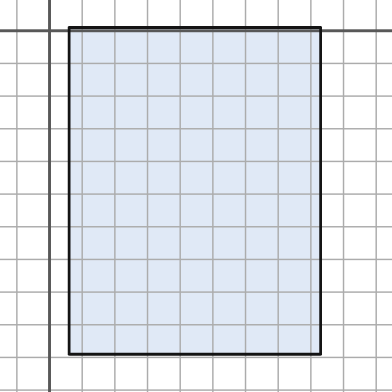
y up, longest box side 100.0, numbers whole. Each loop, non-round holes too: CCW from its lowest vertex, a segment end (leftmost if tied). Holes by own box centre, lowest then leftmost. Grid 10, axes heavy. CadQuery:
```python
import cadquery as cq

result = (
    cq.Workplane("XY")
    .moveTo(6.0, -99.0)
    .lineTo(83.0, -99.0)
    .lineTo(83.0, 1.0)
    .lineTo(6.0, 1.0)
    .close()
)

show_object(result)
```